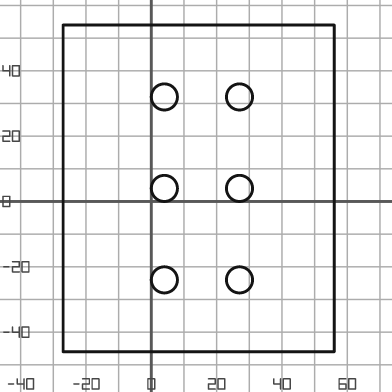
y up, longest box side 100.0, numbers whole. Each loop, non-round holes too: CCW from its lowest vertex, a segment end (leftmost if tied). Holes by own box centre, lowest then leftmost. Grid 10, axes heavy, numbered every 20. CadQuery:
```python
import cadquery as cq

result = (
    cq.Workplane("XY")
    .moveTo(-27.0, -46.0)
    .lineTo(56.0, -46.0)
    .lineTo(56.0, 54.0)
    .lineTo(-27.0, 54.0)
    .close()
    .moveTo(4.0, -24.0)
    .circle(4.0)
    .moveTo(27.0, -24.0)
    .circle(4.0)
    .moveTo(4.0, 4.0)
    .circle(4.0)
    .moveTo(27.0, 4.0)
    .circle(4.0)
    .moveTo(4.0, 32.0)
    .circle(4.0)
    .moveTo(27.0, 32.0)
    .circle(4.0)
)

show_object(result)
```